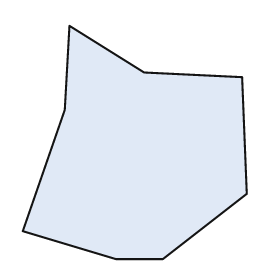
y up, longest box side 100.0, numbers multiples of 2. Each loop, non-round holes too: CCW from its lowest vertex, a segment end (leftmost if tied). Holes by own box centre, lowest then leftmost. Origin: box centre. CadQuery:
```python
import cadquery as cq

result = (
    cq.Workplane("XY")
    .moveTo(-8.0, -50.0)
    .lineTo(12.0, -50.0)
    .lineTo(48.0, -22.0)
    .lineTo(46.0, 28.0)
    .lineTo(4.0, 30.0)
    .lineTo(-28.0, 50.0)
    .lineTo(-30.0, 14.0)
    .lineTo(-48.0, -38.0)
    .close()
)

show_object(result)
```